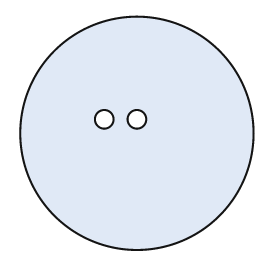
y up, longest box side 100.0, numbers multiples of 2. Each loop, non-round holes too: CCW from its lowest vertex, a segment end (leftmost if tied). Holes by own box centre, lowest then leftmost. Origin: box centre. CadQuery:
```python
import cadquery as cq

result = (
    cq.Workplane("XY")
    .moveTo(0.0, 0.0)
    .circle(50.0)
    .moveTo(-14.0, 6.0)
    .circle(4.0)
    .moveTo(0.0, 6.0)
    .circle(4.0)
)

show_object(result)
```